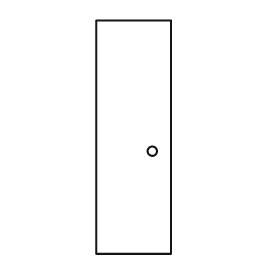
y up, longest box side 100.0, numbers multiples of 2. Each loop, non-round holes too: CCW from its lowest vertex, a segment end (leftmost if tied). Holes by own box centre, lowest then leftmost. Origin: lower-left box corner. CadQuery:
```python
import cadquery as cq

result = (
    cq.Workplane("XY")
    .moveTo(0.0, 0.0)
    .lineTo(32.0, 0.0)
    .lineTo(32.0, 100.0)
    .lineTo(0.0, 100.0)
    .close()
    .moveTo(24.0, 44.0)
    .circle(2.0)
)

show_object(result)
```